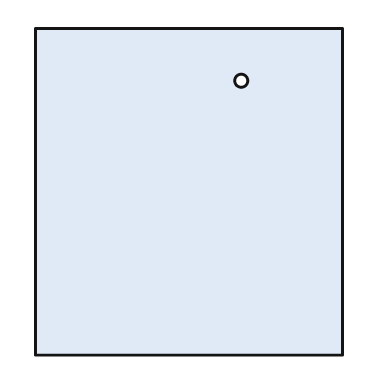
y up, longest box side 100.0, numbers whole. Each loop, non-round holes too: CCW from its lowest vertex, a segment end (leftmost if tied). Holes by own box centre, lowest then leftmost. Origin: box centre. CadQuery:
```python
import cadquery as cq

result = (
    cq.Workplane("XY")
    .moveTo(-47.0, -50.0)
    .lineTo(47.0, -50.0)
    .lineTo(47.0, 50.0)
    .lineTo(-47.0, 50.0)
    .close()
    .moveTo(16.0, 34.0)
    .circle(2.0)
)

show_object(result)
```